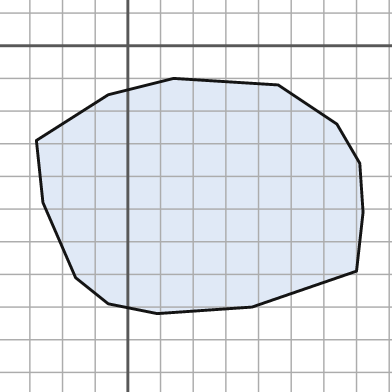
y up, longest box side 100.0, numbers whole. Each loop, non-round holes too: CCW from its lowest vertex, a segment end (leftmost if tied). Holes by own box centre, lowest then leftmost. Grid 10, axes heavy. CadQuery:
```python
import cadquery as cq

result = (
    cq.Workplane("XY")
    .moveTo(9.0, -82.0)
    .lineTo(38.0, -80.0)
    .lineTo(70.0, -69.0)
    .lineTo(72.0, -51.0)
    .lineTo(71.0, -36.0)
    .lineTo(64.0, -24.0)
    .lineTo(46.0, -12.0)
    .lineTo(14.0, -10.0)
    .lineTo(-6.0, -15.0)
    .lineTo(-28.0, -29.0)
    .lineTo(-26.0, -48.0)
    .lineTo(-16.0, -71.0)
    .lineTo(-6.0, -79.0)
    .close()
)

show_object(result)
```